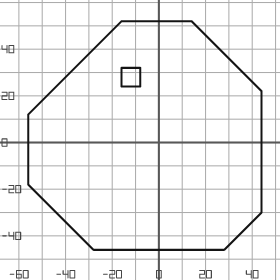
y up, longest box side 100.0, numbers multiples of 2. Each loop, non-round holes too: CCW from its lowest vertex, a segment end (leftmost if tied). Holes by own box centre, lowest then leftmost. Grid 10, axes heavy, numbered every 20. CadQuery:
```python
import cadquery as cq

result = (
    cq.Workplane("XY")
    .moveTo(-28.0, -46.0)
    .lineTo(28.0, -46.0)
    .lineTo(44.0, -30.0)
    .lineTo(44.0, 22.0)
    .lineTo(14.0, 52.0)
    .lineTo(-16.0, 52.0)
    .lineTo(-56.0, 12.0)
    .lineTo(-56.0, -18.0)
    .close()
    .moveTo(-16.0, 24.0)
    .lineTo(-8.0, 24.0)
    .lineTo(-8.0, 32.0)
    .lineTo(-16.0, 32.0)
    .close()
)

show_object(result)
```